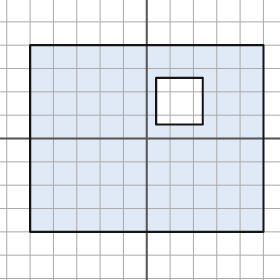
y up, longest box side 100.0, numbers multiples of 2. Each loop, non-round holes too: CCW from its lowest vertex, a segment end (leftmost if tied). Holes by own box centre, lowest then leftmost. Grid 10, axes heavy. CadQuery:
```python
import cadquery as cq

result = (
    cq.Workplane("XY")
    .moveTo(-50.0, -40.0)
    .lineTo(50.0, -40.0)
    .lineTo(50.0, 40.0)
    .lineTo(-50.0, 40.0)
    .close()
    .moveTo(4.0, 6.0)
    .lineTo(24.0, 6.0)
    .lineTo(24.0, 26.0)
    .lineTo(4.0, 26.0)
    .close()
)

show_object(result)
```